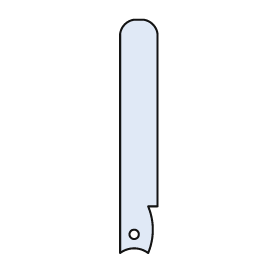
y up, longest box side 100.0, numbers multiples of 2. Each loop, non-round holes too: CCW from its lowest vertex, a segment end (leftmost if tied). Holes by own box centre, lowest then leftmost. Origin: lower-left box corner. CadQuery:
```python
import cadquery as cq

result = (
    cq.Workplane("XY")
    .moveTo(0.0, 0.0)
    .threePointArc((6.0, 2.0), (12.0, 0.0))
    .threePointArc((14.0, 10.0), (12.0, 20.0))
    .lineTo(16.0, 20.0)
    .lineTo(16.0, 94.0)
    .threePointArc((14.0, 98.0), (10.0, 100.0))
    .lineTo(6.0, 100.0)
    .threePointArc((2.0, 98.0), (0.0, 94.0))
    .close()
    .moveTo(6.0, 8.0)
    .circle(2.0)
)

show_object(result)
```